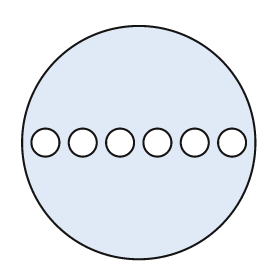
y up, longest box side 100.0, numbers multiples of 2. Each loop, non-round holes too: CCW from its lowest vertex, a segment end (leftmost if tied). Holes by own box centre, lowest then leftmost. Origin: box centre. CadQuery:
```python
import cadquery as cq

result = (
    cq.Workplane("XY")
    .moveTo(0.0, 0.0)
    .circle(50.0)
    .moveTo(-40.0, 0.0)
    .circle(6.0)
    .moveTo(-24.0, 0.0)
    .circle(6.0)
    .moveTo(-8.0, 0.0)
    .circle(6.0)
    .moveTo(8.0, 0.0)
    .circle(6.0)
    .moveTo(24.0, 0.0)
    .circle(6.0)
    .moveTo(40.0, 0.0)
    .circle(6.0)
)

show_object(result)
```